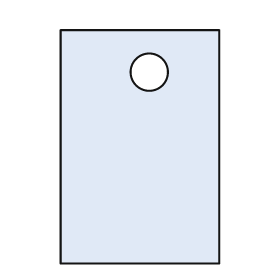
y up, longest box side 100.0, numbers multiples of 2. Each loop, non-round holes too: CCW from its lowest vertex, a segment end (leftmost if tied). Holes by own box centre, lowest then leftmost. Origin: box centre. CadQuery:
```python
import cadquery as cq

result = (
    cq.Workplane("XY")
    .moveTo(-34.0, -50.0)
    .lineTo(34.0, -50.0)
    .lineTo(34.0, 50.0)
    .lineTo(-34.0, 50.0)
    .close()
    .moveTo(4.0, 32.0)
    .circle(8.0)
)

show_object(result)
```